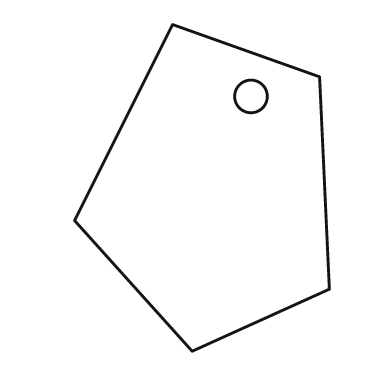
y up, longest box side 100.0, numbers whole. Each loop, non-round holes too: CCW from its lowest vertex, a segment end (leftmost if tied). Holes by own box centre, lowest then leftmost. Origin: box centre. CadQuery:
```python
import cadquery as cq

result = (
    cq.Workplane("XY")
    .moveTo(-3.0, -50.0)
    .lineTo(39.0, -31.0)
    .lineTo(36.0, 34.0)
    .lineTo(-9.0, 50.0)
    .lineTo(-39.0, -10.0)
    .close()
    .moveTo(15.0, 28.0)
    .circle(5.0)
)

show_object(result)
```